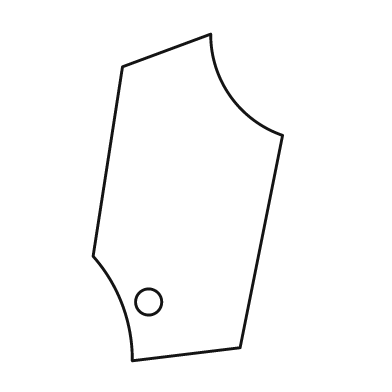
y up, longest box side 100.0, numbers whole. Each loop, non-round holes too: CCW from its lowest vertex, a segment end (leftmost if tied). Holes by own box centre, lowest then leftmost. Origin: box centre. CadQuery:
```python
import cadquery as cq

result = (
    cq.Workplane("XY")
    .moveTo(-17.0, -50.0)
    .lineTo(16.0, -46.0)
    .lineTo(29.0, 19.0)
    .threePointArc((13.0, 31.0), (7.0, 50.0))
    .lineTo(-20.0, 40.0)
    .lineTo(-29.0, -18.0)
    .threePointArc((-20.0, -33.0), (-17.0, -50.0))
    .close()
    .moveTo(-12.0, -32.0)
    .circle(4.0)
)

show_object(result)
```